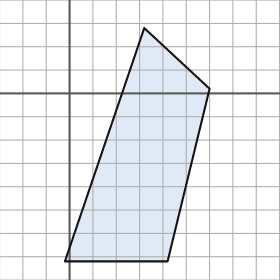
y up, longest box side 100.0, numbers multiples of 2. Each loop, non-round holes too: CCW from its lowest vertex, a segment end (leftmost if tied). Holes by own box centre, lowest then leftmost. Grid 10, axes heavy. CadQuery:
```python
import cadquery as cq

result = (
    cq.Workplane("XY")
    .moveTo(-2.0, -72.0)
    .lineTo(42.0, -72.0)
    .lineTo(60.0, 2.0)
    .lineTo(32.0, 28.0)
    .close()
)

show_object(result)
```